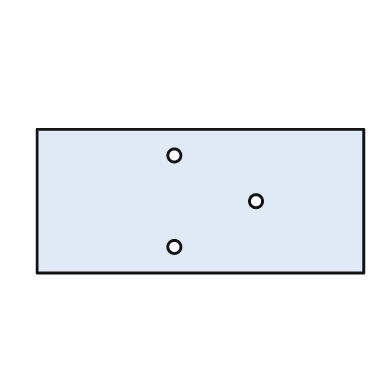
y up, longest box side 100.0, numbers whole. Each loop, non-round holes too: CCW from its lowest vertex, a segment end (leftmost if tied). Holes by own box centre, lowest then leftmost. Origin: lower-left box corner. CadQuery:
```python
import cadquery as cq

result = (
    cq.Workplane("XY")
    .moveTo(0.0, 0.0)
    .lineTo(100.0, 0.0)
    .lineTo(100.0, 44.0)
    .lineTo(0.0, 44.0)
    .close()
    .moveTo(42.0, 8.0)
    .circle(2.0)
    .moveTo(67.0, 22.0)
    .circle(2.0)
    .moveTo(42.0, 36.0)
    .circle(2.0)
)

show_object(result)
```